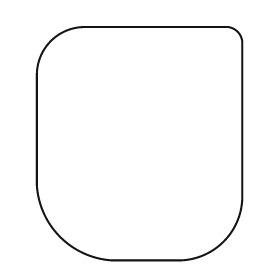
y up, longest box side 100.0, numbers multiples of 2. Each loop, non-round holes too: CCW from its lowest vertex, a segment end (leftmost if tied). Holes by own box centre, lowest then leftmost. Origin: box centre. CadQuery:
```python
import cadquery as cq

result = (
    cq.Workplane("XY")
    .moveTo(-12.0, -50.0)
    .lineTo(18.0, -50.0)
    .threePointArc((36.0, -42.0), (44.0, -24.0))
    .lineTo(44.0, 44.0)
    .threePointArc((42.0, 48.0), (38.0, 50.0))
    .lineTo(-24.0, 50.0)
    .threePointArc((-38.0, 44.0), (-44.0, 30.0))
    .lineTo(-44.0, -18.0)
    .threePointArc((-34.0, -40.0), (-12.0, -50.0))
    .close()
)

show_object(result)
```